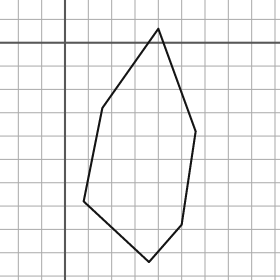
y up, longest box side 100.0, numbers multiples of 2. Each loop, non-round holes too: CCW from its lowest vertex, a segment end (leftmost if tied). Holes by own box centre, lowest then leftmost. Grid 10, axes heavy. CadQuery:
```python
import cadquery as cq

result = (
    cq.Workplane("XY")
    .moveTo(36.0, -94.0)
    .lineTo(50.0, -78.0)
    .lineTo(56.0, -38.0)
    .lineTo(40.0, 6.0)
    .lineTo(16.0, -28.0)
    .lineTo(8.0, -68.0)
    .close()
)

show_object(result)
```